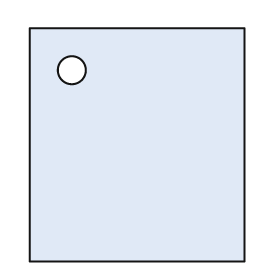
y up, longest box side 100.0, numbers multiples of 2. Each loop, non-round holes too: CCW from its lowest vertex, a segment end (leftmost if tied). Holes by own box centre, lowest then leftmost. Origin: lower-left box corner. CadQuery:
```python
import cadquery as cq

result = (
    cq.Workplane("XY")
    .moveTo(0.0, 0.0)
    .lineTo(92.0, 0.0)
    .lineTo(92.0, 100.0)
    .lineTo(0.0, 100.0)
    .close()
    .moveTo(18.0, 82.0)
    .circle(6.0)
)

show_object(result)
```